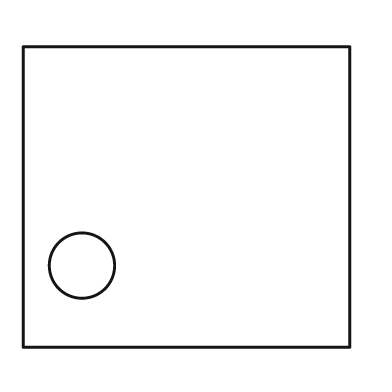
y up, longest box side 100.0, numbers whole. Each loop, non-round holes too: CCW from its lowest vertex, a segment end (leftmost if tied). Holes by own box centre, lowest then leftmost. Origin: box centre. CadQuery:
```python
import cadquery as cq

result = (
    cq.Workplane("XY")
    .moveTo(-50.0, -46.0)
    .lineTo(50.0, -46.0)
    .lineTo(50.0, 46.0)
    .lineTo(-50.0, 46.0)
    .close()
    .moveTo(-32.0, -21.0)
    .circle(10.0)
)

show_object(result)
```